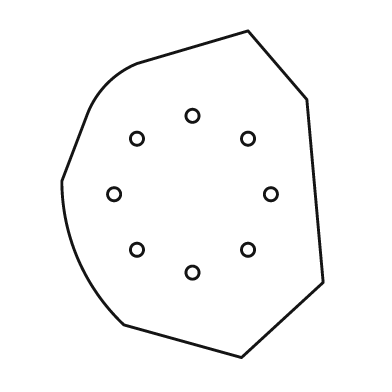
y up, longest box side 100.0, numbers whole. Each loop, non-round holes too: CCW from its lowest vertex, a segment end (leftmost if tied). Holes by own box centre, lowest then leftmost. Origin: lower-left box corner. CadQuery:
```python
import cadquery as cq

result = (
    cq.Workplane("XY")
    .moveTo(55.0, 0.0)
    .lineTo(80.0, 23.0)
    .lineTo(75.0, 79.0)
    .lineTo(57.0, 100.0)
    .lineTo(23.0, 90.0)
    .threePointArc((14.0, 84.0), (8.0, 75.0))
    .lineTo(0.0, 54.0)
    .threePointArc((5.0, 30.0), (19.0, 10.0))
    .close()
    .moveTo(40.0, 26.0)
    .circle(2.0)
    .moveTo(23.0, 33.0)
    .circle(2.0)
    .moveTo(57.0, 33.0)
    .circle(2.0)
    .moveTo(16.0, 50.0)
    .circle(2.0)
    .moveTo(64.0, 50.0)
    .circle(2.0)
    .moveTo(23.0, 67.0)
    .circle(2.0)
    .moveTo(57.0, 67.0)
    .circle(2.0)
    .moveTo(40.0, 74.0)
    .circle(2.0)
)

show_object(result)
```